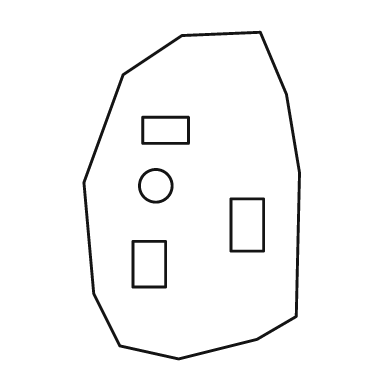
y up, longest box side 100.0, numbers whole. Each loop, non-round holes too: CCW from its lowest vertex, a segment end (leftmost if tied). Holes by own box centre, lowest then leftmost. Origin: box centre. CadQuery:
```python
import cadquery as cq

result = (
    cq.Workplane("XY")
    .moveTo(-4.0, -50.0)
    .lineTo(20.0, -44.0)
    .lineTo(32.0, -37.0)
    .lineTo(33.0, 7.0)
    .lineTo(29.0, 31.0)
    .lineTo(21.0, 50.0)
    .lineTo(-3.0, 49.0)
    .lineTo(-21.0, 37.0)
    .lineTo(-33.0, 4.0)
    .lineTo(-30.0, -30.0)
    .lineTo(-22.0, -46.0)
    .close()
    .moveTo(-18.0, -28.0)
    .lineTo(-8.0, -28.0)
    .lineTo(-8.0, -14.0)
    .lineTo(-18.0, -14.0)
    .close()
    .moveTo(12.0, -17.0)
    .lineTo(22.0, -17.0)
    .lineTo(22.0, -1.0)
    .lineTo(12.0, -1.0)
    .close()
    .moveTo(-11.0, 3.0)
    .circle(5.0)
    .moveTo(-15.0, 16.0)
    .lineTo(-1.0, 16.0)
    .lineTo(-1.0, 24.0)
    .lineTo(-15.0, 24.0)
    .close()
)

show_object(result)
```